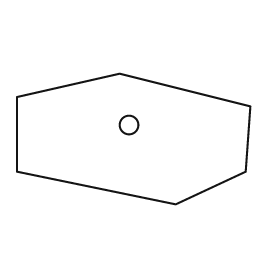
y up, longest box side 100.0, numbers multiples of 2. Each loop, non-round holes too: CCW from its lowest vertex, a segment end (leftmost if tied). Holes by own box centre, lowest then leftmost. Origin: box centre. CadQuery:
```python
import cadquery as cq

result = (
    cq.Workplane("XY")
    .moveTo(18.0, -28.0)
    .lineTo(48.0, -14.0)
    .lineTo(50.0, 14.0)
    .lineTo(-6.0, 28.0)
    .lineTo(-50.0, 18.0)
    .lineTo(-50.0, -14.0)
    .close()
    .moveTo(-2.0, 6.0)
    .circle(4.0)
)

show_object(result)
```